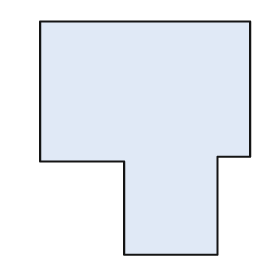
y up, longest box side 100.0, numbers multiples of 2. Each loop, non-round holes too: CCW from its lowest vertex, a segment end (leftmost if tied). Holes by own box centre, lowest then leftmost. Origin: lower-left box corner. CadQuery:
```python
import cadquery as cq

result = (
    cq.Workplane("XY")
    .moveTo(36.0, 0.0)
    .lineTo(76.0, 0.0)
    .lineTo(76.0, 42.0)
    .lineTo(90.0, 42.0)
    .lineTo(90.0, 100.0)
    .lineTo(0.0, 100.0)
    .lineTo(0.0, 40.0)
    .lineTo(36.0, 40.0)
    .close()
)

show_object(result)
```